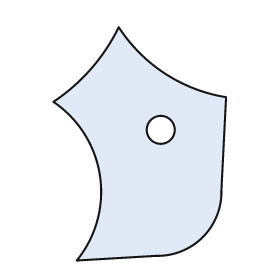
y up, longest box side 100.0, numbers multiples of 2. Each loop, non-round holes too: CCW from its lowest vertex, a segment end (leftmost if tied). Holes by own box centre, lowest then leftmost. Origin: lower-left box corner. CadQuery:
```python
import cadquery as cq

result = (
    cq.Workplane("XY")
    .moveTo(10.0, 0.0)
    .lineTo(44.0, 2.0)
    .threePointArc((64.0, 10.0), (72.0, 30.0))
    .lineTo(74.0, 70.0)
    .threePointArc((48.0, 80.0), (28.0, 100.0))
    .threePointArc((16.0, 82.0), (0.0, 68.0))
    .threePointArc((20.0, 36.0), (10.0, 0.0))
    .close()
    .moveTo(46.0, 56.0)
    .circle(6.0)
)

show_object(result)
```